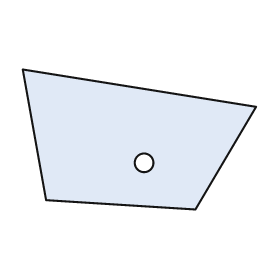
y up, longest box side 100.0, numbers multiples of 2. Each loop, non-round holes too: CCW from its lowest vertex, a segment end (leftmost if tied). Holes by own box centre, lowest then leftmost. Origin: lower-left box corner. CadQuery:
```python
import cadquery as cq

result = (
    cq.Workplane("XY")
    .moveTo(74.0, 0.0)
    .lineTo(100.0, 44.0)
    .lineTo(0.0, 60.0)
    .lineTo(10.0, 4.0)
    .close()
    .moveTo(52.0, 20.0)
    .circle(4.0)
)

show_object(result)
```